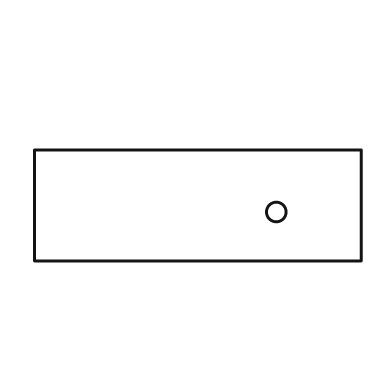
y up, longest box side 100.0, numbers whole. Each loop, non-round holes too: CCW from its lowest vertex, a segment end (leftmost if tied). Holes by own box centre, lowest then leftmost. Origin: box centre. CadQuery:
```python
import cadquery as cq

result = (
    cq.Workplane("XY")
    .moveTo(-50.0, -17.0)
    .lineTo(50.0, -17.0)
    .lineTo(50.0, 17.0)
    .lineTo(-50.0, 17.0)
    .close()
    .moveTo(24.0, -2.0)
    .circle(3.0)
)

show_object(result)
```